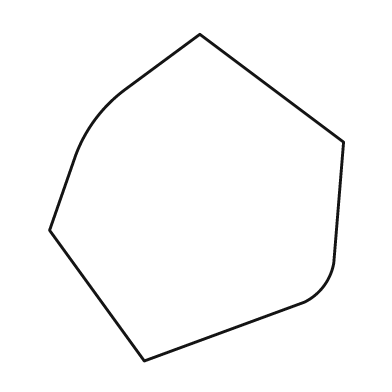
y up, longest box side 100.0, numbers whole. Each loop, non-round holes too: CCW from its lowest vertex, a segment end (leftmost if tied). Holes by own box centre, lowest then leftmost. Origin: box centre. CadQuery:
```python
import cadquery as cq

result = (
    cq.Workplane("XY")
    .moveTo(-16.0, -50.0)
    .lineTo(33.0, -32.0)
    .threePointArc((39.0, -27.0), (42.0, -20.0))
    .lineTo(45.0, 17.0)
    .lineTo(1.0, 50.0)
    .lineTo(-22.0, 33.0)
    .threePointArc((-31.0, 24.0), (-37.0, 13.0))
    .lineTo(-45.0, -10.0)
    .close()
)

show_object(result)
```